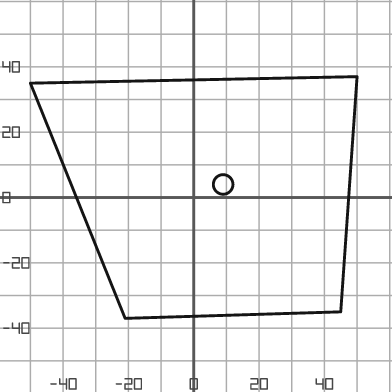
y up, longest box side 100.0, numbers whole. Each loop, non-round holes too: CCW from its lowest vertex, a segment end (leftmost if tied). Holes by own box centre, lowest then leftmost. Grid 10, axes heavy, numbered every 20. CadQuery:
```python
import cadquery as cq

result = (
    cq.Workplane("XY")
    .moveTo(-21.0, -37.0)
    .lineTo(45.0, -35.0)
    .lineTo(50.0, 37.0)
    .lineTo(-50.0, 35.0)
    .close()
    .moveTo(9.0, 4.0)
    .circle(3.0)
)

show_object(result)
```